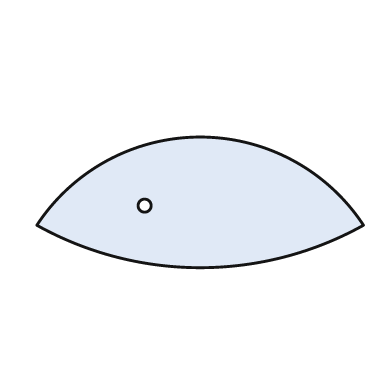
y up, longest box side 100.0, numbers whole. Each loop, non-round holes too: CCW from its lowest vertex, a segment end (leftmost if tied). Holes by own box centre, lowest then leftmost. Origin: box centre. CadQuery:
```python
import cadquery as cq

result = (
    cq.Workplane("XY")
    .moveTo(-50.0, -7.0)
    .threePointArc((0.0, -20.0), (50.0, -7.0))
    .threePointArc((0.0, 20.0), (-50.0, -7.0))
    .close()
    .moveTo(-17.0, -1.0)
    .circle(2.0)
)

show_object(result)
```